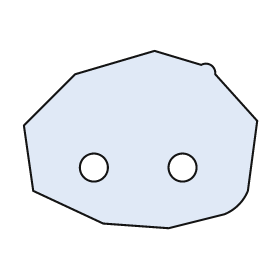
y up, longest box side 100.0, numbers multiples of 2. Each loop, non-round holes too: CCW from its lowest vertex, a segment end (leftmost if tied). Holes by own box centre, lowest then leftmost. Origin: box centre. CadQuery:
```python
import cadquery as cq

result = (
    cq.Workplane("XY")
    .moveTo(12.0, -38.0)
    .lineTo(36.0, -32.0)
    .threePointArc((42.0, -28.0), (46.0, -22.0))
    .lineTo(50.0, 8.0)
    .lineTo(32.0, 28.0)
    .threePointArc((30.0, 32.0), (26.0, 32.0))
    .lineTo(6.0, 38.0)
    .lineTo(-28.0, 28.0)
    .lineTo(-50.0, 6.0)
    .lineTo(-46.0, -22.0)
    .lineTo(-16.0, -36.0)
    .close()
    .moveTo(-20.0, -12.0)
    .circle(6.0)
    .moveTo(18.0, -12.0)
    .circle(6.0)
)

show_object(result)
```